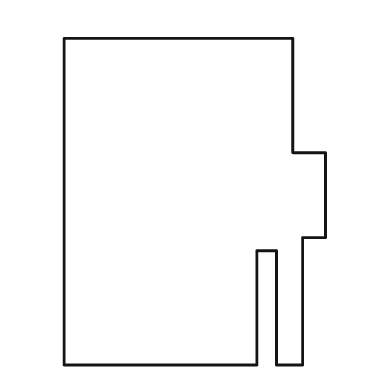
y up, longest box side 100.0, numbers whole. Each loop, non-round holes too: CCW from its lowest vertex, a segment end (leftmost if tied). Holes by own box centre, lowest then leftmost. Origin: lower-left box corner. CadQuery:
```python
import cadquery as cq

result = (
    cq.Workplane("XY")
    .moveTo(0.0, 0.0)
    .lineTo(59.0, 0.0)
    .lineTo(59.0, 35.0)
    .lineTo(65.0, 35.0)
    .lineTo(65.0, 0.0)
    .lineTo(73.0, 0.0)
    .lineTo(73.0, 39.0)
    .lineTo(80.0, 39.0)
    .lineTo(80.0, 65.0)
    .lineTo(70.0, 65.0)
    .lineTo(70.0, 100.0)
    .lineTo(0.0, 100.0)
    .close()
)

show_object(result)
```